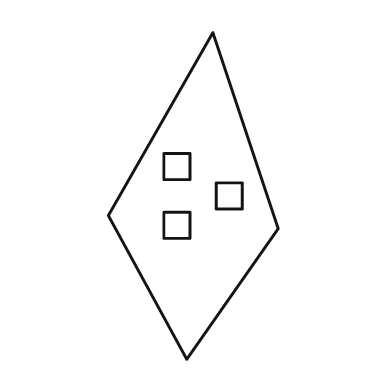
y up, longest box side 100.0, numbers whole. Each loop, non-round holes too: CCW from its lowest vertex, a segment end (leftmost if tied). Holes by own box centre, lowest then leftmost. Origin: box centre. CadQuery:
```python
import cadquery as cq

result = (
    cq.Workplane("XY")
    .moveTo(-2.0, -50.0)
    .lineTo(26.0, -10.0)
    .lineTo(6.0, 50.0)
    .lineTo(-26.0, -6.0)
    .close()
    .moveTo(-9.0, -13.0)
    .lineTo(-1.0, -13.0)
    .lineTo(-1.0, -5.0)
    .lineTo(-9.0, -5.0)
    .close()
    .moveTo(7.0, -4.0)
    .lineTo(15.0, -4.0)
    .lineTo(15.0, 4.0)
    .lineTo(7.0, 4.0)
    .close()
    .moveTo(-9.0, 5.0)
    .lineTo(-1.0, 5.0)
    .lineTo(-1.0, 13.0)
    .lineTo(-9.0, 13.0)
    .close()
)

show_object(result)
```